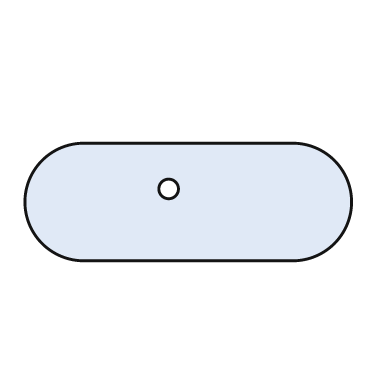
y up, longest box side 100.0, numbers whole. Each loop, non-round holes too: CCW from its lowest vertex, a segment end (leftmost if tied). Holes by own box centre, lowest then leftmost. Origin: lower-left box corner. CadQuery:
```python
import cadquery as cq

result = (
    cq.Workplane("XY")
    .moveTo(18.0, 0.0)
    .lineTo(82.0, 0.0)
    .threePointArc((100.0, 18.0), (82.0, 36.0))
    .lineTo(18.0, 36.0)
    .threePointArc((0.0, 18.0), (18.0, 0.0))
    .close()
    .moveTo(44.0, 22.0)
    .circle(3.0)
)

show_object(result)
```